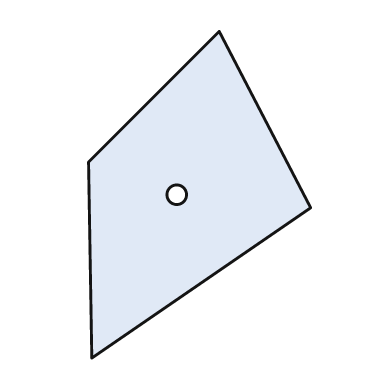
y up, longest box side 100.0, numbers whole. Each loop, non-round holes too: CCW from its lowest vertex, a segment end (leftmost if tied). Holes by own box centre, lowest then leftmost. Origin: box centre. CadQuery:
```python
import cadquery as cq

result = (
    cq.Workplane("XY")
    .moveTo(-33.0, -50.0)
    .lineTo(34.0, -4.0)
    .lineTo(6.0, 50.0)
    .lineTo(-34.0, 10.0)
    .close()
    .moveTo(-7.0, 0.0)
    .circle(3.0)
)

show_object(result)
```